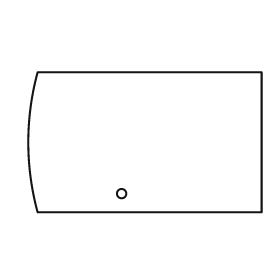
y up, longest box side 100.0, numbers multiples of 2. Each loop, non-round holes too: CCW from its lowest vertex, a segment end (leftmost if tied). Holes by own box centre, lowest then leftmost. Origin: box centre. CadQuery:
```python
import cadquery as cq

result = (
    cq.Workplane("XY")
    .moveTo(-46.0, -30.0)
    .lineTo(50.0, -30.0)
    .lineTo(50.0, 30.0)
    .lineTo(-46.0, 30.0)
    .threePointArc((-50.0, 0.0), (-46.0, -30.0))
    .close()
    .moveTo(-10.0, -22.0)
    .circle(2.0)
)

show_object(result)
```